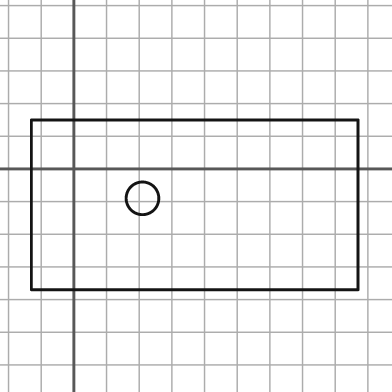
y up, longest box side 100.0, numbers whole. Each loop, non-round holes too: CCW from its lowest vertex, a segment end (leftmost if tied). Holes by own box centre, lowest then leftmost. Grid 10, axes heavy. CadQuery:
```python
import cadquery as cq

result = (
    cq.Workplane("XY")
    .moveTo(-13.0, -37.0)
    .lineTo(87.0, -37.0)
    .lineTo(87.0, 15.0)
    .lineTo(-13.0, 15.0)
    .close()
    .moveTo(21.0, -9.0)
    .circle(5.0)
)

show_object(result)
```